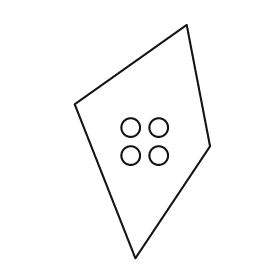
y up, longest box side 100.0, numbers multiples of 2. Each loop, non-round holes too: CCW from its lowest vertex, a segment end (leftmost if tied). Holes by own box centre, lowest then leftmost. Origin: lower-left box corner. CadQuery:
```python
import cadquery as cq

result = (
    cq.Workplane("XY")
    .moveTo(26.0, 0.0)
    .lineTo(58.0, 48.0)
    .lineTo(48.0, 100.0)
    .lineTo(0.0, 66.0)
    .close()
    .moveTo(24.0, 44.0)
    .circle(4.0)
    .moveTo(36.0, 44.0)
    .circle(4.0)
    .moveTo(24.0, 56.0)
    .circle(4.0)
    .moveTo(36.0, 56.0)
    .circle(4.0)
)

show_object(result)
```